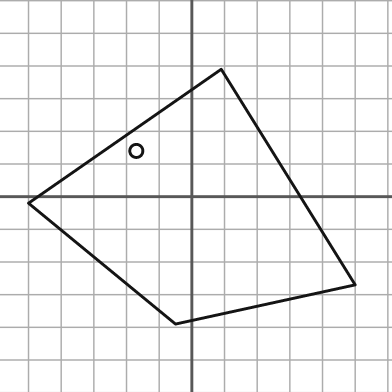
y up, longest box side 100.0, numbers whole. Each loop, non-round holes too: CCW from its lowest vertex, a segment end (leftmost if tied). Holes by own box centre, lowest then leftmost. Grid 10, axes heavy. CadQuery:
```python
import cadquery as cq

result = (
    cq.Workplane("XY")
    .moveTo(-5.0, -39.0)
    .lineTo(50.0, -27.0)
    .lineTo(9.0, 39.0)
    .lineTo(-50.0, -2.0)
    .close()
    .moveTo(-17.0, 14.0)
    .circle(2.0)
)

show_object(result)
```